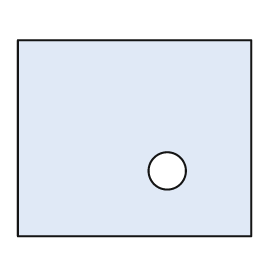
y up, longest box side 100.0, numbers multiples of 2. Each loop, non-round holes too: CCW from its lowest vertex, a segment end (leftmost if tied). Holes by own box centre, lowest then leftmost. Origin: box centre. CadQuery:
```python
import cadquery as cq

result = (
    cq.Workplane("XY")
    .moveTo(-50.0, -42.0)
    .lineTo(50.0, -42.0)
    .lineTo(50.0, 42.0)
    .lineTo(-50.0, 42.0)
    .close()
    .moveTo(14.0, -14.0)
    .circle(8.0)
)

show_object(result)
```